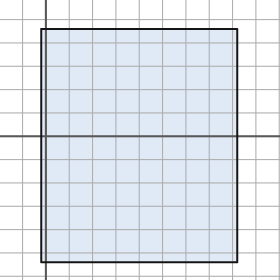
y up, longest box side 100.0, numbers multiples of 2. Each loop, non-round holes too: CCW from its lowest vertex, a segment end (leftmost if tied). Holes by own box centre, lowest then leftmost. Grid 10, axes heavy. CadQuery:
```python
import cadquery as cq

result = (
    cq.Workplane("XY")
    .moveTo(-2.0, -54.0)
    .lineTo(82.0, -54.0)
    .lineTo(82.0, 46.0)
    .lineTo(-2.0, 46.0)
    .close()
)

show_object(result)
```